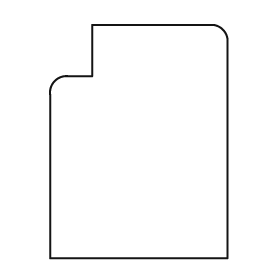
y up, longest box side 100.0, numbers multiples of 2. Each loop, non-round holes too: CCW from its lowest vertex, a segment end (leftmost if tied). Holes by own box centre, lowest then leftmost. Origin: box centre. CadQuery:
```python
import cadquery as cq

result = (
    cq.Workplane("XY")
    .moveTo(-38.0, -50.0)
    .lineTo(38.0, -50.0)
    .lineTo(38.0, 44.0)
    .threePointArc((36.0, 48.0), (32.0, 50.0))
    .lineTo(-20.0, 50.0)
    .lineTo(-20.0, 28.0)
    .lineTo(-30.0, 28.0)
    .threePointArc((-36.0, 26.0), (-38.0, 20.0))
    .close()
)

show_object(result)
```